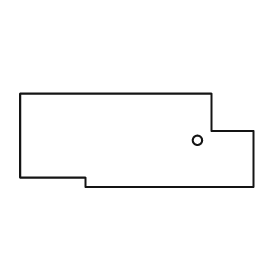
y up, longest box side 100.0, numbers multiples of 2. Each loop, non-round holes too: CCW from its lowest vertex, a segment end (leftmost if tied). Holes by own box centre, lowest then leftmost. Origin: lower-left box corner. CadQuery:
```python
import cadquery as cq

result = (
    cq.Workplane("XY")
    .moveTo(28.0, 0.0)
    .lineTo(100.0, 0.0)
    .lineTo(100.0, 24.0)
    .lineTo(82.0, 24.0)
    .lineTo(82.0, 40.0)
    .lineTo(0.0, 40.0)
    .lineTo(0.0, 4.0)
    .lineTo(28.0, 4.0)
    .close()
    .moveTo(76.0, 20.0)
    .circle(2.0)
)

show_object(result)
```